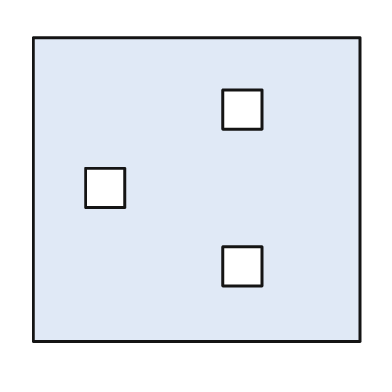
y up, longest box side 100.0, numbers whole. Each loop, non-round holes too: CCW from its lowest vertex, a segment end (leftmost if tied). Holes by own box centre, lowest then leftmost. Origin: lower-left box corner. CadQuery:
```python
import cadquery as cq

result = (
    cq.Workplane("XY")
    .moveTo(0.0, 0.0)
    .lineTo(100.0, 0.0)
    .lineTo(100.0, 93.0)
    .lineTo(0.0, 93.0)
    .close()
    .moveTo(58.0, 17.0)
    .lineTo(70.0, 17.0)
    .lineTo(70.0, 29.0)
    .lineTo(58.0, 29.0)
    .close()
    .moveTo(16.0, 41.0)
    .lineTo(28.0, 41.0)
    .lineTo(28.0, 53.0)
    .lineTo(16.0, 53.0)
    .close()
    .moveTo(58.0, 65.0)
    .lineTo(70.0, 65.0)
    .lineTo(70.0, 77.0)
    .lineTo(58.0, 77.0)
    .close()
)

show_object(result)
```